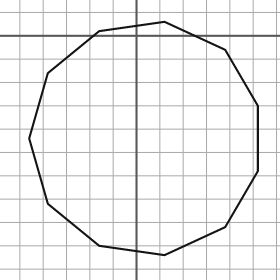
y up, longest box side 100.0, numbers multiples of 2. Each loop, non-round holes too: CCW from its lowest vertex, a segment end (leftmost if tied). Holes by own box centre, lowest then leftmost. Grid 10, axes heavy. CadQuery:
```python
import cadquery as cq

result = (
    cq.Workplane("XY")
    .moveTo(12.0, -94.0)
    .lineTo(38.0, -82.0)
    .lineTo(52.0, -58.0)
    .lineTo(52.0, -30.0)
    .lineTo(38.0, -6.0)
    .lineTo(12.0, 6.0)
    .lineTo(-16.0, 2.0)
    .lineTo(-38.0, -16.0)
    .lineTo(-46.0, -44.0)
    .lineTo(-38.0, -72.0)
    .lineTo(-16.0, -90.0)
    .close()
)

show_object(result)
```